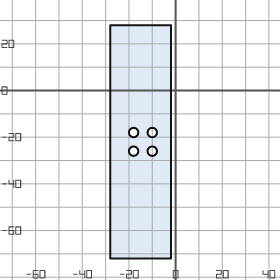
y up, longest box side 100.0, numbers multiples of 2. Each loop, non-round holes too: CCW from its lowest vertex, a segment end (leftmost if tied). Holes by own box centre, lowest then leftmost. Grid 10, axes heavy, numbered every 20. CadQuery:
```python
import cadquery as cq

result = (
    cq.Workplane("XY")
    .moveTo(-28.0, -72.0)
    .lineTo(-2.0, -72.0)
    .lineTo(-2.0, 28.0)
    .lineTo(-28.0, 28.0)
    .close()
    .moveTo(-18.0, -26.0)
    .circle(2.0)
    .moveTo(-10.0, -26.0)
    .circle(2.0)
    .moveTo(-18.0, -18.0)
    .circle(2.0)
    .moveTo(-10.0, -18.0)
    .circle(2.0)
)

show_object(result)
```